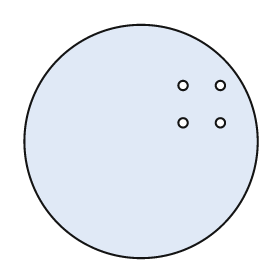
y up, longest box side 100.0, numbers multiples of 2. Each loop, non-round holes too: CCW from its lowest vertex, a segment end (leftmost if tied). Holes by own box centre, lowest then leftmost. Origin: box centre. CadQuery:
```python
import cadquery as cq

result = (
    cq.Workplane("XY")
    .moveTo(0.0, 0.0)
    .circle(50.0)
    .moveTo(18.0, 8.0)
    .circle(2.0)
    .moveTo(34.0, 8.0)
    .circle(2.0)
    .moveTo(18.0, 24.0)
    .circle(2.0)
    .moveTo(34.0, 24.0)
    .circle(2.0)
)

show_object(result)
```